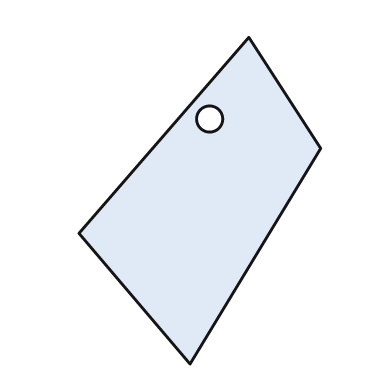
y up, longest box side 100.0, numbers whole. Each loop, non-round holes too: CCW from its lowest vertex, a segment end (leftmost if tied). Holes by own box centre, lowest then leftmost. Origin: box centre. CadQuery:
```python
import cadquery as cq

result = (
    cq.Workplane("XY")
    .moveTo(-3.0, -50.0)
    .lineTo(37.0, 16.0)
    .lineTo(15.0, 50.0)
    .lineTo(-37.0, -10.0)
    .close()
    .moveTo(3.0, 25.0)
    .circle(4.0)
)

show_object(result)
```